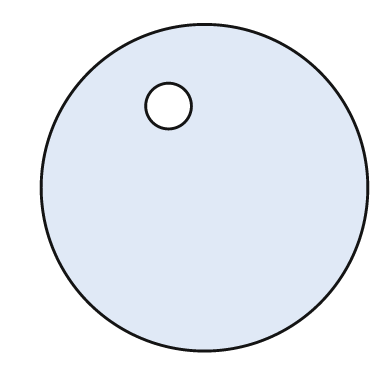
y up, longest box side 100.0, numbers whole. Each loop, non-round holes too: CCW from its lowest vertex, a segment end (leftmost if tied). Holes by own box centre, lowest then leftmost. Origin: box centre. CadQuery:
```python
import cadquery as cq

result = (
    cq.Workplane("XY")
    .moveTo(0.0, 0.0)
    .circle(50.0)
    .moveTo(-11.0, 25.0)
    .circle(7.0)
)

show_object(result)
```